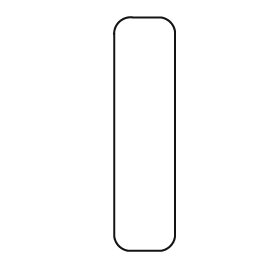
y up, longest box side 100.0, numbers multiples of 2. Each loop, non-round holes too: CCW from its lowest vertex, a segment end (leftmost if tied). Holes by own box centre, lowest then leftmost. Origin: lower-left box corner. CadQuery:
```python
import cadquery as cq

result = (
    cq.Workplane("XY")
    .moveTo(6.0, 0.0)
    .lineTo(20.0, 0.0)
    .threePointArc((24.0, 2.0), (26.0, 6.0))
    .lineTo(26.0, 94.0)
    .threePointArc((24.0, 98.0), (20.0, 100.0))
    .lineTo(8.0, 100.0)
    .threePointArc((2.0, 98.0), (0.0, 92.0))
    .lineTo(0.0, 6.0)
    .threePointArc((2.0, 2.0), (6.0, 0.0))
    .close()
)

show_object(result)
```